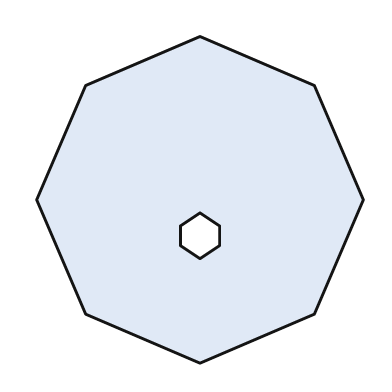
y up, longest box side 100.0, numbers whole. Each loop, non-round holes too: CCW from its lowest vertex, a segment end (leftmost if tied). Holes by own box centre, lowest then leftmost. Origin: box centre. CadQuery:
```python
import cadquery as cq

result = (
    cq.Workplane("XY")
    .moveTo(0.0, -50.0)
    .lineTo(35.0, -35.0)
    .lineTo(50.0, 0.0)
    .lineTo(35.0, 35.0)
    .lineTo(0.0, 50.0)
    .lineTo(-35.0, 35.0)
    .lineTo(-50.0, 0.0)
    .lineTo(-35.0, -35.0)
    .close()
    .moveTo(0.0, -18.0)
    .lineTo(6.0, -14.0)
    .lineTo(6.0, -8.0)
    .lineTo(0.0, -4.0)
    .lineTo(-6.0, -8.0)
    .lineTo(-6.0, -14.0)
    .close()
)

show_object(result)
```